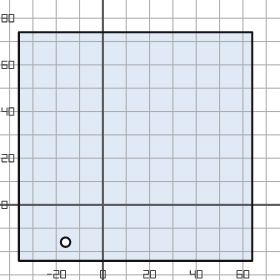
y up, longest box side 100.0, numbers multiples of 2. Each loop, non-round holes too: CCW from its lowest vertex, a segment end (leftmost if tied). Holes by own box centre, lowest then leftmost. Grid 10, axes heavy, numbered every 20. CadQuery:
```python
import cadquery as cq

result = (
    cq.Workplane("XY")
    .moveTo(-36.0, -24.0)
    .lineTo(64.0, -24.0)
    .lineTo(64.0, 74.0)
    .lineTo(-36.0, 74.0)
    .close()
    .moveTo(-16.0, -16.0)
    .circle(2.0)
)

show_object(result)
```